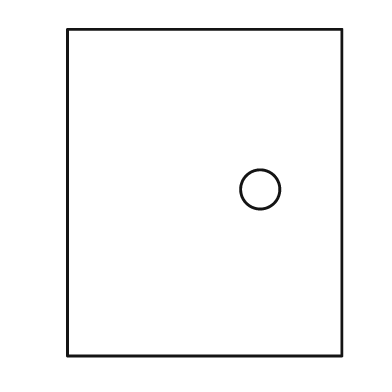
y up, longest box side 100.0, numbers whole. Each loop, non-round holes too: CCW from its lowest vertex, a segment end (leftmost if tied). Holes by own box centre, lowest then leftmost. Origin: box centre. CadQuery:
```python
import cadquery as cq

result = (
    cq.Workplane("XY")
    .moveTo(-42.0, -50.0)
    .lineTo(42.0, -50.0)
    .lineTo(42.0, 50.0)
    .lineTo(-42.0, 50.0)
    .close()
    .moveTo(17.0, 1.0)
    .circle(6.0)
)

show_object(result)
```